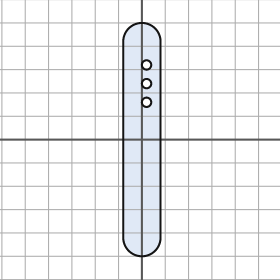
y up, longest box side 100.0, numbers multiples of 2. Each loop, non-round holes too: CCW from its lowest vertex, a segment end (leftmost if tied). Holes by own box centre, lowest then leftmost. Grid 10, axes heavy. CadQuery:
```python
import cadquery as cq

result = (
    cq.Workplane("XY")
    .moveTo(-8.0, -42.0)
    .threePointArc((0.0, -50.0), (8.0, -42.0))
    .lineTo(8.0, 42.0)
    .threePointArc((0.0, 50.0), (-8.0, 42.0))
    .close()
    .moveTo(2.0, 16.0)
    .circle(2.0)
    .moveTo(2.0, 24.0)
    .circle(2.0)
    .moveTo(2.0, 32.0)
    .circle(2.0)
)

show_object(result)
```